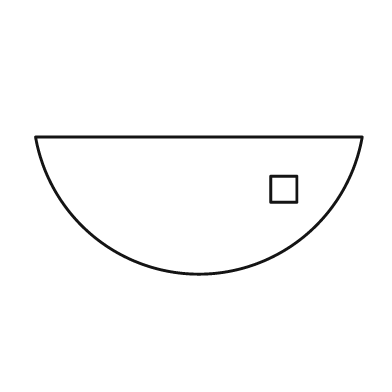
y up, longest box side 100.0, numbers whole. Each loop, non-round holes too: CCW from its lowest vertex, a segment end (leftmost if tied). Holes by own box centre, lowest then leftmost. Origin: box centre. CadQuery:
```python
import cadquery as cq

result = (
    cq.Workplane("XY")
    .moveTo(-50.0, 21.0)
    .threePointArc((0.0, -21.0), (50.0, 21.0))
    .close()
    .moveTo(22.0, 1.0)
    .lineTo(30.0, 1.0)
    .lineTo(30.0, 9.0)
    .lineTo(22.0, 9.0)
    .close()
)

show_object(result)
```